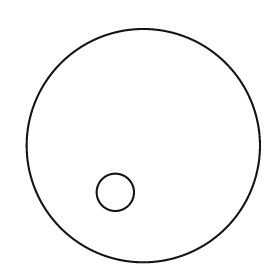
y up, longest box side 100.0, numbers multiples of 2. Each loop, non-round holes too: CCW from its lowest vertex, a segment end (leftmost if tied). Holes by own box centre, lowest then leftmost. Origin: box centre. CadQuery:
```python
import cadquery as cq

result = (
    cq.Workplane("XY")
    .moveTo(0.0, 0.0)
    .circle(50.0)
    .moveTo(-12.0, -20.0)
    .circle(8.0)
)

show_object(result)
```